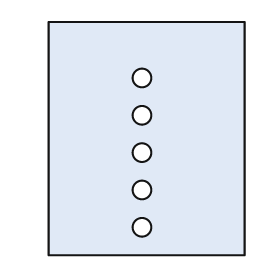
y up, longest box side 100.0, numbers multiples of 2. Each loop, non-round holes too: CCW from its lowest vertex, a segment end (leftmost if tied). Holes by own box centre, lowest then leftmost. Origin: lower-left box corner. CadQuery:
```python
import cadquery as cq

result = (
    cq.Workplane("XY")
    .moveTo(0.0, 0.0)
    .lineTo(84.0, 0.0)
    .lineTo(84.0, 100.0)
    .lineTo(0.0, 100.0)
    .close()
    .moveTo(40.0, 12.0)
    .circle(4.0)
    .moveTo(40.0, 28.0)
    .circle(4.0)
    .moveTo(40.0, 44.0)
    .circle(4.0)
    .moveTo(40.0, 60.0)
    .circle(4.0)
    .moveTo(40.0, 76.0)
    .circle(4.0)
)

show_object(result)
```